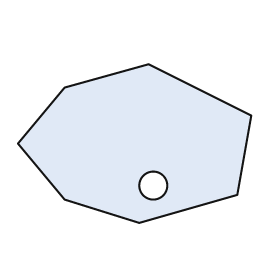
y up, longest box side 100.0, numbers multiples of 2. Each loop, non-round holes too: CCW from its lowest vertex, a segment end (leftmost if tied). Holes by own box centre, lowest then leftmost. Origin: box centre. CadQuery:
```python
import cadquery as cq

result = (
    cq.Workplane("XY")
    .moveTo(2.0, -34.0)
    .lineTo(44.0, -22.0)
    .lineTo(50.0, 12.0)
    .lineTo(6.0, 34.0)
    .lineTo(-30.0, 24.0)
    .lineTo(-50.0, 0.0)
    .lineTo(-30.0, -24.0)
    .close()
    .moveTo(8.0, -18.0)
    .circle(6.0)
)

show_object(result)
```